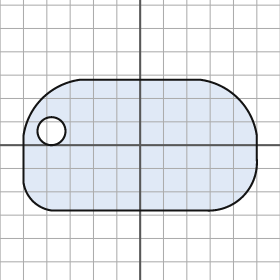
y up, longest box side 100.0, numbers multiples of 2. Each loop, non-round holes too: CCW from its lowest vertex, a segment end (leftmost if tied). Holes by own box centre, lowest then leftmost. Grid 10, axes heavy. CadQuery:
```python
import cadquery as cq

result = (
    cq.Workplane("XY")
    .moveTo(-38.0, -28.0)
    .lineTo(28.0, -28.0)
    .threePointArc((44.0, -22.0), (50.0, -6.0))
    .lineTo(50.0, 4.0)
    .threePointArc((42.0, 20.0), (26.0, 28.0))
    .lineTo(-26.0, 28.0)
    .threePointArc((-42.0, 20.0), (-50.0, 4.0))
    .lineTo(-50.0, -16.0)
    .threePointArc((-46.0, -24.0), (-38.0, -28.0))
    .close()
    .moveTo(-38.0, 6.0)
    .circle(6.0)
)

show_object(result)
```